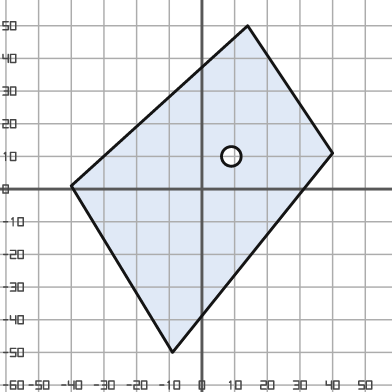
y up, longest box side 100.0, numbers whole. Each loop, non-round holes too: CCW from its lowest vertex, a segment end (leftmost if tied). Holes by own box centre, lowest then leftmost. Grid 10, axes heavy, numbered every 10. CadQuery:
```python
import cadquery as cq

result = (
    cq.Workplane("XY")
    .moveTo(-9.0, -50.0)
    .lineTo(40.0, 11.0)
    .lineTo(14.0, 50.0)
    .lineTo(-40.0, 1.0)
    .close()
    .moveTo(9.0, 10.0)
    .circle(3.0)
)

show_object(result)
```